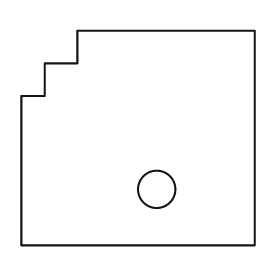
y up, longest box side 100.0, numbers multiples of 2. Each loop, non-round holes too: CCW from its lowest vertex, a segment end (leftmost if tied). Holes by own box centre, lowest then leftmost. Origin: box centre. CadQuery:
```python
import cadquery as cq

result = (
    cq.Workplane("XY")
    .moveTo(-50.0, -46.0)
    .lineTo(50.0, -46.0)
    .lineTo(50.0, 46.0)
    .lineTo(-26.0, 46.0)
    .lineTo(-26.0, 32.0)
    .lineTo(-40.0, 32.0)
    .lineTo(-40.0, 18.0)
    .lineTo(-50.0, 18.0)
    .close()
    .moveTo(8.0, -22.0)
    .circle(8.0)
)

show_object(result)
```